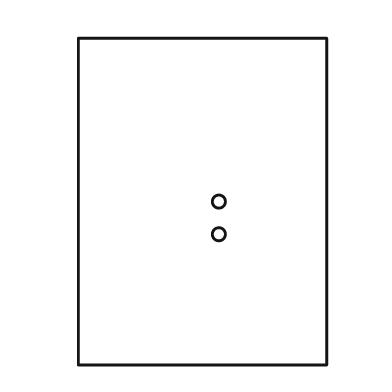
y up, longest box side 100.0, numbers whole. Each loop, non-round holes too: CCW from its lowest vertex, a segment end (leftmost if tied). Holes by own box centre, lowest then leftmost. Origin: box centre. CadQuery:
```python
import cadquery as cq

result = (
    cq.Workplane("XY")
    .moveTo(-38.0, -50.0)
    .lineTo(38.0, -50.0)
    .lineTo(38.0, 50.0)
    .lineTo(-38.0, 50.0)
    .close()
    .moveTo(5.0, -10.0)
    .circle(2.0)
    .moveTo(5.0, 0.0)
    .circle(2.0)
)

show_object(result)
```